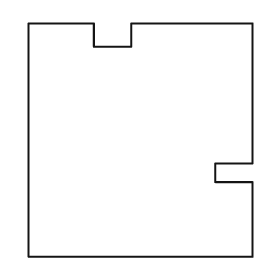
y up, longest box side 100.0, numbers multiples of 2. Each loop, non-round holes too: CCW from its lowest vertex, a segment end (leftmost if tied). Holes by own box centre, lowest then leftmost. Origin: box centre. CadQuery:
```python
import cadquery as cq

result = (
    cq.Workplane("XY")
    .moveTo(-48.0, -50.0)
    .lineTo(48.0, -50.0)
    .lineTo(48.0, -18.0)
    .lineTo(32.0, -18.0)
    .lineTo(32.0, -10.0)
    .lineTo(48.0, -10.0)
    .lineTo(48.0, 50.0)
    .lineTo(-4.0, 50.0)
    .lineTo(-4.0, 40.0)
    .lineTo(-20.0, 40.0)
    .lineTo(-20.0, 50.0)
    .lineTo(-48.0, 50.0)
    .close()
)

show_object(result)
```